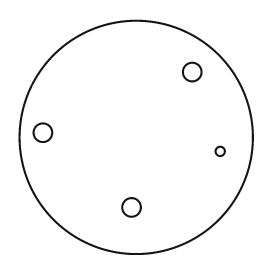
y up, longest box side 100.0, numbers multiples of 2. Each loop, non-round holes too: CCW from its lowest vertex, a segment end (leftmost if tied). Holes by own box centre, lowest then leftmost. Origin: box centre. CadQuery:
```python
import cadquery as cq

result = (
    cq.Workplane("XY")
    .moveTo(0.0, 0.0)
    .circle(50.0)
    .moveTo(-2.0, -30.0)
    .circle(4.0)
    .moveTo(36.0, -6.0)
    .circle(2.0)
    .moveTo(-40.0, 2.0)
    .circle(4.0)
    .moveTo(24.0, 28.0)
    .circle(4.0)
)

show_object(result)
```